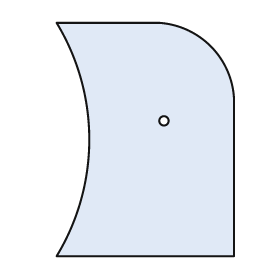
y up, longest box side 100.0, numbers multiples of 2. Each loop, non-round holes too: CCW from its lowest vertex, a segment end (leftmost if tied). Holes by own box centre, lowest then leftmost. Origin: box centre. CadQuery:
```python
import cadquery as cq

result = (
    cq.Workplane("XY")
    .moveTo(-38.0, -50.0)
    .lineTo(38.0, -50.0)
    .lineTo(38.0, 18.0)
    .threePointArc((28.0, 40.0), (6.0, 50.0))
    .lineTo(-38.0, 50.0)
    .threePointArc((-24.0, 0.0), (-38.0, -50.0))
    .close()
    .moveTo(8.0, 8.0)
    .circle(2.0)
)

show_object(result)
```